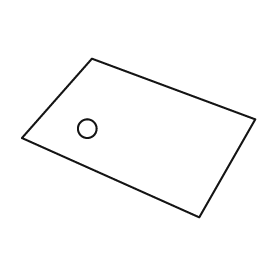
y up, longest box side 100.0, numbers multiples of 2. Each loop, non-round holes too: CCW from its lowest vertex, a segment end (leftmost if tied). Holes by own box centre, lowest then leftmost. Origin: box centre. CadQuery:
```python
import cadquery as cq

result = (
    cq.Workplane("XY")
    .moveTo(26.0, -34.0)
    .lineTo(50.0, 8.0)
    .lineTo(-20.0, 34.0)
    .lineTo(-50.0, 0.0)
    .close()
    .moveTo(-22.0, 4.0)
    .circle(4.0)
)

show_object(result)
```